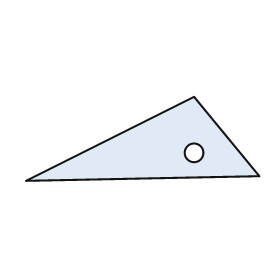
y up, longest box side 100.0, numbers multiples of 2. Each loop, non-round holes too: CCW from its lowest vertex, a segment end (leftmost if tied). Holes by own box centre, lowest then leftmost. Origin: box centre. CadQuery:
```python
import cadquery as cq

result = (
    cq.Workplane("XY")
    .moveTo(-50.0, -18.0)
    .lineTo(50.0, -16.0)
    .lineTo(22.0, 18.0)
    .close()
    .moveTo(22.0, -6.0)
    .circle(4.0)
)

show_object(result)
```